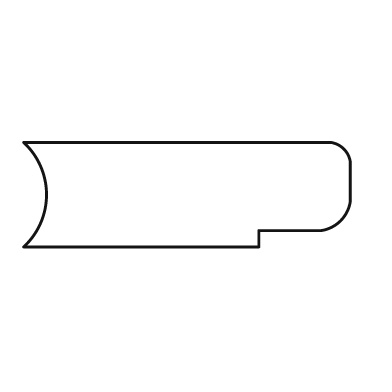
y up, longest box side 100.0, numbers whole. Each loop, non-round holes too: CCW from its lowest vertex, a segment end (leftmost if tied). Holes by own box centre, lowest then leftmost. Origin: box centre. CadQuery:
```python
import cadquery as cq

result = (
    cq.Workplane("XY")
    .moveTo(-50.0, -16.0)
    .lineTo(22.0, -16.0)
    .lineTo(22.0, -11.0)
    .lineTo(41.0, -11.0)
    .threePointArc((47.0, -8.0), (50.0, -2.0))
    .lineTo(50.0, 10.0)
    .threePointArc((48.0, 14.0), (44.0, 16.0))
    .lineTo(-50.0, 16.0)
    .threePointArc((-43.0, 0.0), (-50.0, -16.0))
    .close()
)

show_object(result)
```